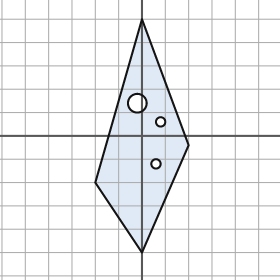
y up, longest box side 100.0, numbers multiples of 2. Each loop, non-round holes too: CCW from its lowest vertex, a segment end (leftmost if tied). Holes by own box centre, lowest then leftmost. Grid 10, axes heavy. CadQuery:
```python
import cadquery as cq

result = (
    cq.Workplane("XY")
    .moveTo(0.0, -50.0)
    .lineTo(20.0, -4.0)
    .lineTo(0.0, 50.0)
    .lineTo(-20.0, -20.0)
    .close()
    .moveTo(6.0, -12.0)
    .circle(2.0)
    .moveTo(8.0, 6.0)
    .circle(2.0)
    .moveTo(-2.0, 14.0)
    .circle(4.0)
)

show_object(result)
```